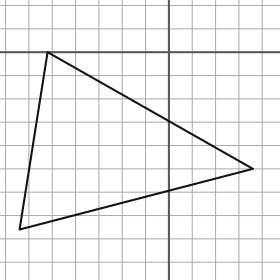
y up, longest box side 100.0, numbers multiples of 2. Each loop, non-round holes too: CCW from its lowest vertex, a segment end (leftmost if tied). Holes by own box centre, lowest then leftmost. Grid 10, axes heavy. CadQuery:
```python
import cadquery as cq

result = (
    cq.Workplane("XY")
    .moveTo(-64.0, -76.0)
    .lineTo(36.0, -50.0)
    .lineTo(-52.0, 0.0)
    .close()
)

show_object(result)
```